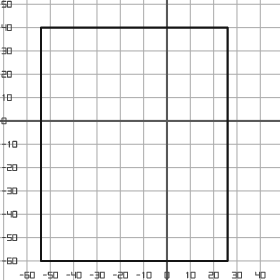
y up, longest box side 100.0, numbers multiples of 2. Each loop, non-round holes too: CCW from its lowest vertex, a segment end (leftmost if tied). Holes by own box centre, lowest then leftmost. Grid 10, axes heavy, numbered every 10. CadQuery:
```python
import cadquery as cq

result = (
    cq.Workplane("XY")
    .moveTo(-54.0, -60.0)
    .lineTo(26.0, -60.0)
    .lineTo(26.0, 40.0)
    .lineTo(-54.0, 40.0)
    .close()
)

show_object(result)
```